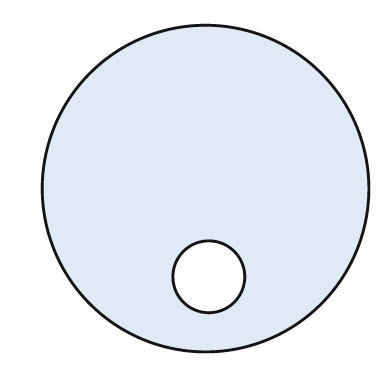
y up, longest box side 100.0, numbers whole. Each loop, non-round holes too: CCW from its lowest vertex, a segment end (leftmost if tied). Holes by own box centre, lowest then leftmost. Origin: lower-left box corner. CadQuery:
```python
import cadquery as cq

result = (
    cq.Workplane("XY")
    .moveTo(50.0, 50.0)
    .circle(50.0)
    .moveTo(51.0, 23.0)
    .circle(11.0)
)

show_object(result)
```